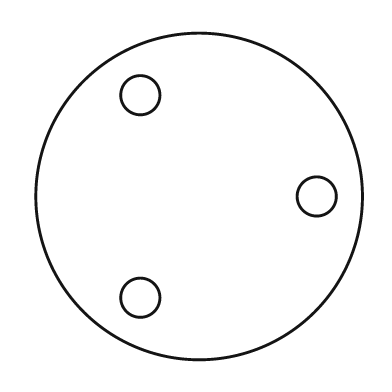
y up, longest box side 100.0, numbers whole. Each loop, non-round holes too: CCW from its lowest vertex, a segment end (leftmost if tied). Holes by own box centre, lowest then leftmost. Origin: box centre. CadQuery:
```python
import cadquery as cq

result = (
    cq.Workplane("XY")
    .moveTo(0.0, 0.0)
    .circle(50.0)
    .moveTo(-18.0, -31.0)
    .circle(6.0)
    .moveTo(36.0, 0.0)
    .circle(6.0)
    .moveTo(-18.0, 31.0)
    .circle(6.0)
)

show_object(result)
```